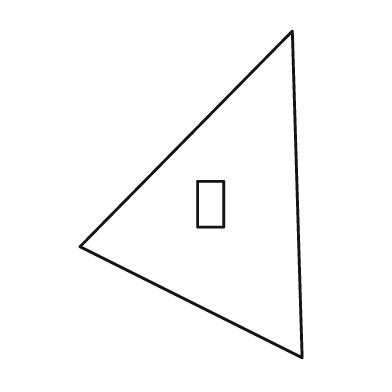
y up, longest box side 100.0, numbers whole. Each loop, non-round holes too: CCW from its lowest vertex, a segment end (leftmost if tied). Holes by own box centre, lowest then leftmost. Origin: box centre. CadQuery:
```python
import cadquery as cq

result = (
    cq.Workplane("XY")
    .moveTo(34.0, -50.0)
    .lineTo(31.0, 50.0)
    .lineTo(-34.0, -16.0)
    .close()
    .moveTo(2.0, -10.0)
    .lineTo(10.0, -10.0)
    .lineTo(10.0, 4.0)
    .lineTo(2.0, 4.0)
    .close()
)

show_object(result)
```